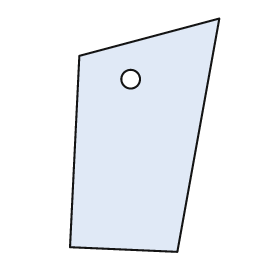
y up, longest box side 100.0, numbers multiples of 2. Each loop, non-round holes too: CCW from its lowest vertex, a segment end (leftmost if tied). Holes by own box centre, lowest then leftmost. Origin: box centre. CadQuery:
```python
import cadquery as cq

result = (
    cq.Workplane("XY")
    .moveTo(14.0, -50.0)
    .lineTo(32.0, 50.0)
    .lineTo(-28.0, 34.0)
    .lineTo(-32.0, -48.0)
    .close()
    .moveTo(-6.0, 24.0)
    .circle(4.0)
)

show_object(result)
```